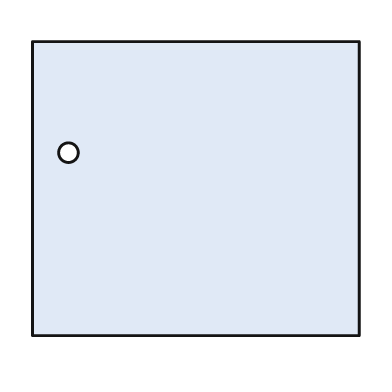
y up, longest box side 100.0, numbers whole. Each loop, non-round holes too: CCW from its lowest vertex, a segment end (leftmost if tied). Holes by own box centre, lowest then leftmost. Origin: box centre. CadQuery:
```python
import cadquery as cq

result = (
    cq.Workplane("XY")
    .moveTo(-50.0, -45.0)
    .lineTo(50.0, -45.0)
    .lineTo(50.0, 45.0)
    .lineTo(-50.0, 45.0)
    .close()
    .moveTo(-39.0, 11.0)
    .circle(3.0)
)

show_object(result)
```